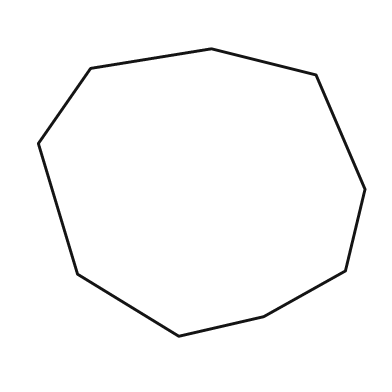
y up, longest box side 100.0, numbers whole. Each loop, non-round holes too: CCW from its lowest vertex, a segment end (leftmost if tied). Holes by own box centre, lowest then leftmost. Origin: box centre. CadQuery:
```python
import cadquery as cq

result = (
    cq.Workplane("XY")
    .moveTo(-7.0, -44.0)
    .lineTo(19.0, -38.0)
    .lineTo(44.0, -24.0)
    .lineTo(50.0, 1.0)
    .lineTo(35.0, 36.0)
    .lineTo(3.0, 44.0)
    .lineTo(-34.0, 38.0)
    .lineTo(-50.0, 15.0)
    .lineTo(-38.0, -25.0)
    .close()
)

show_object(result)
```